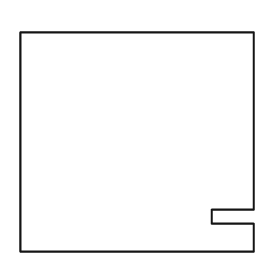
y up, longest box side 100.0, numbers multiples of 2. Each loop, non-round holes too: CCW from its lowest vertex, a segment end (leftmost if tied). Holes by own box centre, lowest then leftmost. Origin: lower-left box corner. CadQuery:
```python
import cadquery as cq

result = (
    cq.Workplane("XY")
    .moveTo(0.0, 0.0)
    .lineTo(100.0, 0.0)
    .lineTo(100.0, 12.0)
    .lineTo(82.0, 12.0)
    .lineTo(82.0, 18.0)
    .lineTo(100.0, 18.0)
    .lineTo(100.0, 94.0)
    .lineTo(0.0, 94.0)
    .close()
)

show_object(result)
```